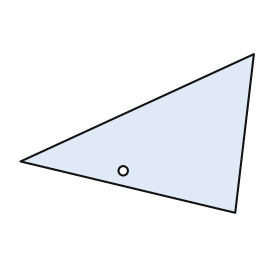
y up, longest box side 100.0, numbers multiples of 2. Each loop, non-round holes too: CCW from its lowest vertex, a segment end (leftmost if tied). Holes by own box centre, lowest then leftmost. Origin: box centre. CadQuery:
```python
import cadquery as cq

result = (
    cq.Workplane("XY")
    .moveTo(42.0, -34.0)
    .lineTo(50.0, 34.0)
    .lineTo(-50.0, -12.0)
    .close()
    .moveTo(-6.0, -16.0)
    .circle(2.0)
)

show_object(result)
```